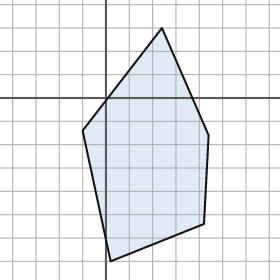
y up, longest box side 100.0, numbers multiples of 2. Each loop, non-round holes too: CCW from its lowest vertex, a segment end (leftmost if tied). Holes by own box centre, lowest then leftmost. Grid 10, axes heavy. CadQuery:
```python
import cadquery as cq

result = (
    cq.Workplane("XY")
    .moveTo(2.0, -70.0)
    .lineTo(42.0, -54.0)
    .lineTo(44.0, -16.0)
    .lineTo(24.0, 30.0)
    .lineTo(-10.0, -14.0)
    .close()
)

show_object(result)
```